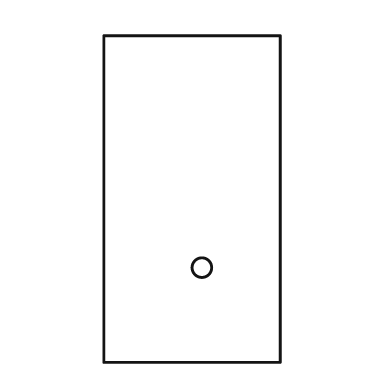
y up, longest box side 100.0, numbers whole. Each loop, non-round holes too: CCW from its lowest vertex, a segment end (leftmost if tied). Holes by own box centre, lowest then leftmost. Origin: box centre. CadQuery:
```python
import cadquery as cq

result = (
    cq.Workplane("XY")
    .moveTo(-27.0, -50.0)
    .lineTo(27.0, -50.0)
    .lineTo(27.0, 50.0)
    .lineTo(-27.0, 50.0)
    .close()
    .moveTo(3.0, -21.0)
    .circle(3.0)
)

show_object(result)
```